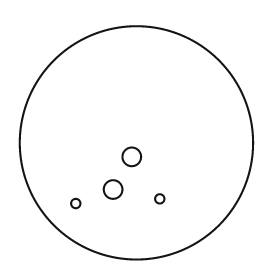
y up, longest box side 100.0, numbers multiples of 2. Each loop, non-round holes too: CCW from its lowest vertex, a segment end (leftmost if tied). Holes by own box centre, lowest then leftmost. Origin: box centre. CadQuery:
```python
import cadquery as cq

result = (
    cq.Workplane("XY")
    .moveTo(0.0, 0.0)
    .circle(50.0)
    .moveTo(-26.0, -26.0)
    .circle(2.0)
    .moveTo(10.0, -24.0)
    .circle(2.0)
    .moveTo(-10.0, -20.0)
    .circle(4.0)
    .moveTo(-2.0, -6.0)
    .circle(4.0)
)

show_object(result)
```